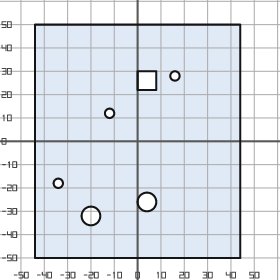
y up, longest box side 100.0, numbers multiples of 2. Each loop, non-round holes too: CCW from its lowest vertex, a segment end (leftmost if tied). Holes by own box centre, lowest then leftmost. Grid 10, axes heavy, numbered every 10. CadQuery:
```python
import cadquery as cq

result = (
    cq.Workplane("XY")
    .moveTo(-44.0, -50.0)
    .lineTo(44.0, -50.0)
    .lineTo(44.0, 50.0)
    .lineTo(-44.0, 50.0)
    .close()
    .moveTo(-20.0, -32.0)
    .circle(4.0)
    .moveTo(4.0, -26.0)
    .circle(4.0)
    .moveTo(-34.0, -18.0)
    .circle(2.0)
    .moveTo(-12.0, 12.0)
    .circle(2.0)
    .moveTo(0.0, 22.0)
    .lineTo(8.0, 22.0)
    .lineTo(8.0, 30.0)
    .lineTo(0.0, 30.0)
    .close()
    .moveTo(16.0, 28.0)
    .circle(2.0)
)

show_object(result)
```